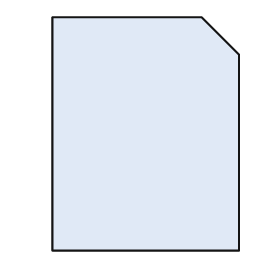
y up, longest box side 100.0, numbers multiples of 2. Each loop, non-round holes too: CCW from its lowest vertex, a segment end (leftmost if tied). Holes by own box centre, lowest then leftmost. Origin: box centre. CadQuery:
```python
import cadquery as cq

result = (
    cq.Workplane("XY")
    .moveTo(-40.0, -50.0)
    .lineTo(40.0, -50.0)
    .lineTo(40.0, 34.0)
    .lineTo(24.0, 50.0)
    .lineTo(-40.0, 50.0)
    .close()
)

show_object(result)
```